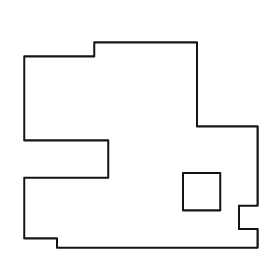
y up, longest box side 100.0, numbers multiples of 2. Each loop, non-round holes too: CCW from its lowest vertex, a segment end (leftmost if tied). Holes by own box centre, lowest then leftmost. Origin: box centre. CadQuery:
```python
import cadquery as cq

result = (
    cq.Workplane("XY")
    .moveTo(-36.0, -44.0)
    .lineTo(50.0, -44.0)
    .lineTo(50.0, -36.0)
    .lineTo(42.0, -36.0)
    .lineTo(42.0, -26.0)
    .lineTo(50.0, -26.0)
    .lineTo(50.0, 8.0)
    .lineTo(24.0, 8.0)
    .lineTo(24.0, 44.0)
    .lineTo(-20.0, 44.0)
    .lineTo(-20.0, 38.0)
    .lineTo(-50.0, 38.0)
    .lineTo(-50.0, 2.0)
    .lineTo(-14.0, 2.0)
    .lineTo(-14.0, -14.0)
    .lineTo(-50.0, -14.0)
    .lineTo(-50.0, -40.0)
    .lineTo(-36.0, -40.0)
    .close()
    .moveTo(18.0, -28.0)
    .lineTo(34.0, -28.0)
    .lineTo(34.0, -12.0)
    .lineTo(18.0, -12.0)
    .close()
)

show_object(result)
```